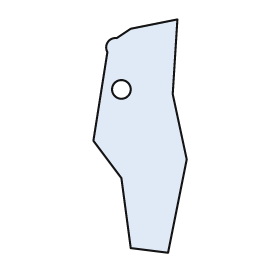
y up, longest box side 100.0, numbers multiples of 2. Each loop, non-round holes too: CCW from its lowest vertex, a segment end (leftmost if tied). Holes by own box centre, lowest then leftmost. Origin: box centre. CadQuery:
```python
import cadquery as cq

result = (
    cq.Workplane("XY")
    .moveTo(12.0, -50.0)
    .lineTo(20.0, -10.0)
    .lineTo(14.0, 18.0)
    .lineTo(16.0, 50.0)
    .lineTo(-4.0, 46.0)
    .lineTo(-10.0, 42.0)
    .threePointArc((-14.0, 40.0), (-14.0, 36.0))
    .lineTo(-20.0, -2.0)
    .lineTo(-8.0, -18.0)
    .lineTo(-4.0, -48.0)
    .close()
    .moveTo(-8.0, 20.0)
    .circle(4.0)
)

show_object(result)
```